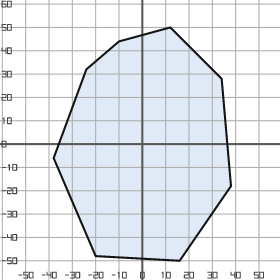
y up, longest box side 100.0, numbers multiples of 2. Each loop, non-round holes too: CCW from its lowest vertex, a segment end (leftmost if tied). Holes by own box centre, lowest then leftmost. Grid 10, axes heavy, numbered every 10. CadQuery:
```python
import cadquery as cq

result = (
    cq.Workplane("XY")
    .moveTo(16.0, -50.0)
    .lineTo(38.0, -18.0)
    .lineTo(34.0, 28.0)
    .lineTo(12.0, 50.0)
    .lineTo(-10.0, 44.0)
    .lineTo(-24.0, 32.0)
    .lineTo(-38.0, -6.0)
    .lineTo(-20.0, -48.0)
    .close()
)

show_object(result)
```